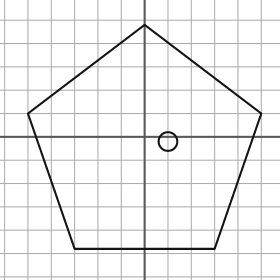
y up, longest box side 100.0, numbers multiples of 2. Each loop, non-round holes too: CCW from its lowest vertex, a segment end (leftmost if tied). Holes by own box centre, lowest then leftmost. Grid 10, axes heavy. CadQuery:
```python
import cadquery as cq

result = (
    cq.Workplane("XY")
    .moveTo(-30.0, -48.0)
    .lineTo(30.0, -48.0)
    .lineTo(50.0, 10.0)
    .lineTo(0.0, 48.0)
    .lineTo(-50.0, 10.0)
    .close()
    .moveTo(10.0, -2.0)
    .circle(4.0)
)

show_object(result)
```